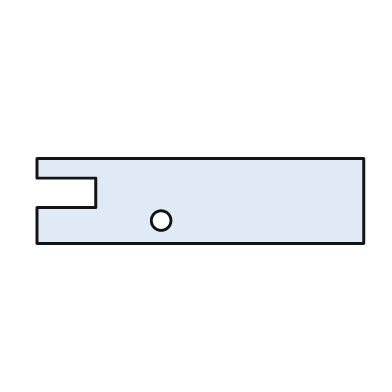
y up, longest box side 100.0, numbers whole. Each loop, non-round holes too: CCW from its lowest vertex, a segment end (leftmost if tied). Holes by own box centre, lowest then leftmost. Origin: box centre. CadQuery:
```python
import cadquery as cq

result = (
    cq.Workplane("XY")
    .moveTo(-50.0, -13.0)
    .lineTo(50.0, -13.0)
    .lineTo(50.0, 13.0)
    .lineTo(-50.0, 13.0)
    .lineTo(-50.0, 7.0)
    .lineTo(-32.0, 7.0)
    .lineTo(-32.0, -2.0)
    .lineTo(-50.0, -2.0)
    .close()
    .moveTo(-12.0, -6.0)
    .circle(3.0)
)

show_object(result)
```